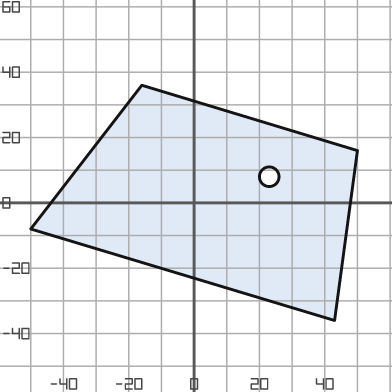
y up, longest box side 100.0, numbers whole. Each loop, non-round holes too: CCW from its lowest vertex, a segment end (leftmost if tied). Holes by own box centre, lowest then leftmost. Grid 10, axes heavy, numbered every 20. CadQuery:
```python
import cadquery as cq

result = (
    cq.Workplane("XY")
    .moveTo(43.0, -36.0)
    .lineTo(50.0, 16.0)
    .lineTo(-16.0, 36.0)
    .lineTo(-50.0, -8.0)
    .close()
    .moveTo(23.0, 8.0)
    .circle(3.0)
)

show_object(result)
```